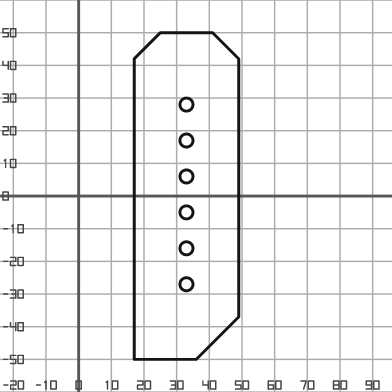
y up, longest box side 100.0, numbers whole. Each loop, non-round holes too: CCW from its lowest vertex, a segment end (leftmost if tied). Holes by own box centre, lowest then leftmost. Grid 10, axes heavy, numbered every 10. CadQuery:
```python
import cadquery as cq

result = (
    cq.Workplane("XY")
    .moveTo(17.0, -50.0)
    .lineTo(36.0, -50.0)
    .lineTo(49.0, -37.0)
    .lineTo(49.0, 42.0)
    .lineTo(41.0, 50.0)
    .lineTo(25.0, 50.0)
    .lineTo(17.0, 42.0)
    .close()
    .moveTo(33.0, -27.0)
    .circle(2.0)
    .moveTo(33.0, -16.0)
    .circle(2.0)
    .moveTo(33.0, -5.0)
    .circle(2.0)
    .moveTo(33.0, 6.0)
    .circle(2.0)
    .moveTo(33.0, 17.0)
    .circle(2.0)
    .moveTo(33.0, 28.0)
    .circle(2.0)
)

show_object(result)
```